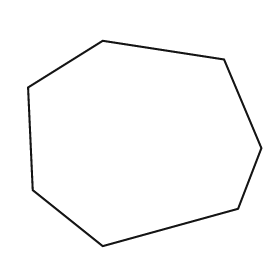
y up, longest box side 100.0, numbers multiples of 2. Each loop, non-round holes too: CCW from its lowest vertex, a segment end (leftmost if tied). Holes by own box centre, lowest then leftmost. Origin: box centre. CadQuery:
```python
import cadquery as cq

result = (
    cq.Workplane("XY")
    .moveTo(-18.0, -44.0)
    .lineTo(40.0, -28.0)
    .lineTo(50.0, -2.0)
    .lineTo(34.0, 36.0)
    .lineTo(-18.0, 44.0)
    .lineTo(-50.0, 24.0)
    .lineTo(-48.0, -20.0)
    .close()
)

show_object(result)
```